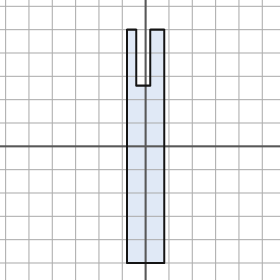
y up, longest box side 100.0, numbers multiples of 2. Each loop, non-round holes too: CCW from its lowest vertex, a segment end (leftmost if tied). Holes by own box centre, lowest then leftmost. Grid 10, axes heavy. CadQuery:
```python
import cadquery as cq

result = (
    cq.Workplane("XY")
    .moveTo(-8.0, -50.0)
    .lineTo(8.0, -50.0)
    .lineTo(8.0, 50.0)
    .lineTo(2.0, 50.0)
    .lineTo(2.0, 26.0)
    .lineTo(-4.0, 26.0)
    .lineTo(-4.0, 50.0)
    .lineTo(-8.0, 50.0)
    .close()
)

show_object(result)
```